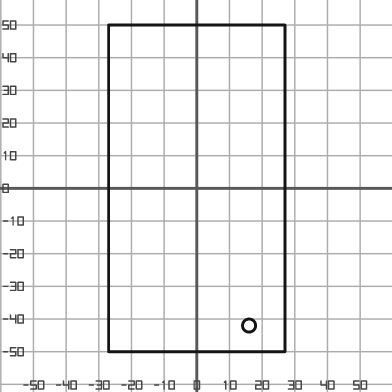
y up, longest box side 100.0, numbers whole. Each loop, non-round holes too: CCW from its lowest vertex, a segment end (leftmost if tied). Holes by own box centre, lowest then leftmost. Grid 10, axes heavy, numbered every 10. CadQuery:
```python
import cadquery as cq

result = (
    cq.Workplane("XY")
    .moveTo(-27.0, -50.0)
    .lineTo(27.0, -50.0)
    .lineTo(27.0, 50.0)
    .lineTo(-27.0, 50.0)
    .close()
    .moveTo(16.0, -42.0)
    .circle(2.0)
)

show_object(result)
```